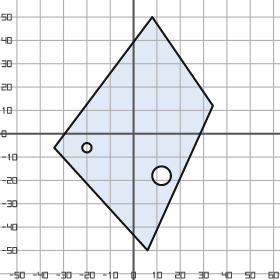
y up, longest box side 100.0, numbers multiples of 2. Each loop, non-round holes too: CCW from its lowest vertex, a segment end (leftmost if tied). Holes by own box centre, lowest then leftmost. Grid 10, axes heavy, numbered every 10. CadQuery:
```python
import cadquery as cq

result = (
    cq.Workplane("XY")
    .moveTo(6.0, -50.0)
    .lineTo(34.0, 12.0)
    .lineTo(8.0, 50.0)
    .lineTo(-34.0, -6.0)
    .close()
    .moveTo(12.0, -18.0)
    .circle(4.0)
    .moveTo(-20.0, -6.0)
    .circle(2.0)
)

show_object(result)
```